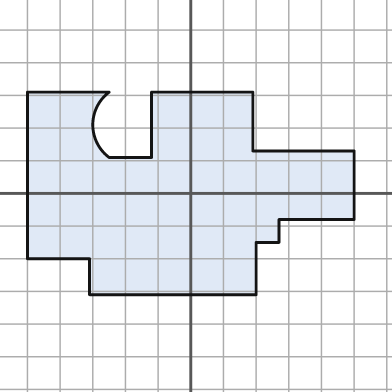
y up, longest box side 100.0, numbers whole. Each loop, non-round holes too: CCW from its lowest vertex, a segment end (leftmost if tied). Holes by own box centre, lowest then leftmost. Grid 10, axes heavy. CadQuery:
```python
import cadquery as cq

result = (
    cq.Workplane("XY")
    .moveTo(-31.0, -31.0)
    .lineTo(20.0, -31.0)
    .lineTo(20.0, -15.0)
    .lineTo(27.0, -15.0)
    .lineTo(27.0, -8.0)
    .lineTo(50.0, -8.0)
    .lineTo(50.0, 13.0)
    .lineTo(19.0, 13.0)
    .lineTo(19.0, 31.0)
    .lineTo(-12.0, 31.0)
    .lineTo(-12.0, 11.0)
    .lineTo(-25.0, 11.0)
    .threePointArc((-30.0, 21.0), (-25.0, 31.0))
    .lineTo(-50.0, 31.0)
    .lineTo(-50.0, -20.0)
    .lineTo(-31.0, -20.0)
    .close()
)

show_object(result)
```